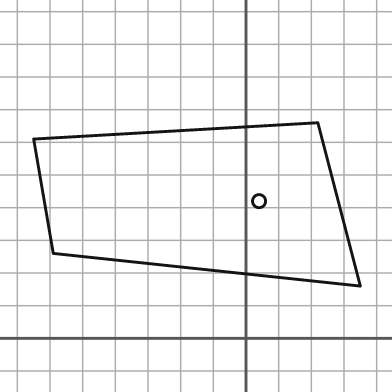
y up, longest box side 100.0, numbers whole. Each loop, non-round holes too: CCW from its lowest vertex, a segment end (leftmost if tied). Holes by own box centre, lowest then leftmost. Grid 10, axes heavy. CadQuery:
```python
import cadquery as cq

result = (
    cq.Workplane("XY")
    .moveTo(35.0, 16.0)
    .lineTo(22.0, 66.0)
    .lineTo(-65.0, 61.0)
    .lineTo(-59.0, 26.0)
    .close()
    .moveTo(4.0, 42.0)
    .circle(2.0)
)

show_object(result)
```